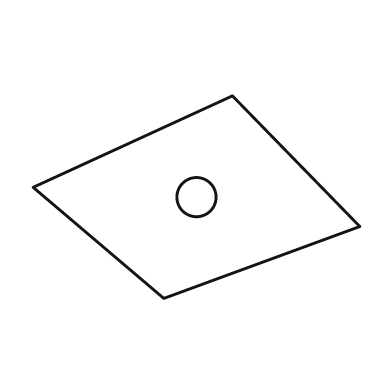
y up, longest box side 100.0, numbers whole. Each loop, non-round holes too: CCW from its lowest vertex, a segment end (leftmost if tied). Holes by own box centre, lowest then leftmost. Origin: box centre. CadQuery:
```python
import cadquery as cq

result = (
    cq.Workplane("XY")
    .moveTo(-10.0, -31.0)
    .lineTo(50.0, -9.0)
    .lineTo(11.0, 31.0)
    .lineTo(-50.0, 3.0)
    .close()
    .moveTo(0.0, 0.0)
    .circle(6.0)
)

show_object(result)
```